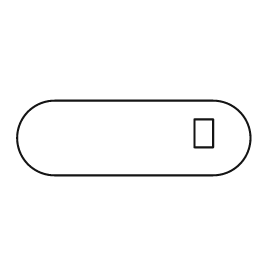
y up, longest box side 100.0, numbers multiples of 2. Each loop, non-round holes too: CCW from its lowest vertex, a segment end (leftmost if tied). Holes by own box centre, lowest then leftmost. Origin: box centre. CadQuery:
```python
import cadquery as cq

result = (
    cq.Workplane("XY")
    .moveTo(-34.0, -16.0)
    .lineTo(34.0, -16.0)
    .threePointArc((50.0, 0.0), (34.0, 16.0))
    .lineTo(-34.0, 16.0)
    .threePointArc((-50.0, 0.0), (-34.0, -16.0))
    .close()
    .moveTo(26.0, -4.0)
    .lineTo(34.0, -4.0)
    .lineTo(34.0, 8.0)
    .lineTo(26.0, 8.0)
    .close()
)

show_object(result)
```